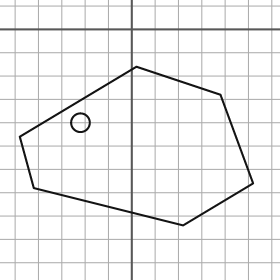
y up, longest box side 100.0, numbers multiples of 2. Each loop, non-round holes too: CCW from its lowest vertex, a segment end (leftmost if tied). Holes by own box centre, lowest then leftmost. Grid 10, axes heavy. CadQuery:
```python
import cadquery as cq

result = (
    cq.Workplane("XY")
    .moveTo(22.0, -84.0)
    .lineTo(52.0, -66.0)
    .lineTo(38.0, -28.0)
    .lineTo(2.0, -16.0)
    .lineTo(-48.0, -46.0)
    .lineTo(-42.0, -68.0)
    .close()
    .moveTo(-22.0, -40.0)
    .circle(4.0)
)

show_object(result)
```